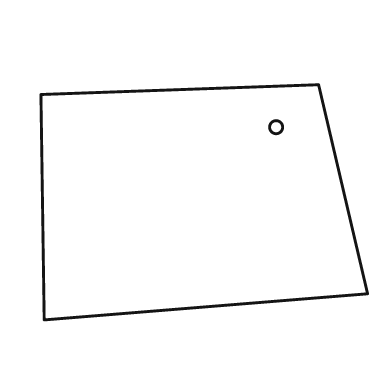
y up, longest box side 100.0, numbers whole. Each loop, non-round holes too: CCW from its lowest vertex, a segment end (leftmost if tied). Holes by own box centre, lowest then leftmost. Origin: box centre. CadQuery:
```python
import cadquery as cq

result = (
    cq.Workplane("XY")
    .moveTo(-49.0, -36.0)
    .lineTo(50.0, -28.0)
    .lineTo(35.0, 36.0)
    .lineTo(-50.0, 33.0)
    .close()
    .moveTo(22.0, 23.0)
    .circle(2.0)
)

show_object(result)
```